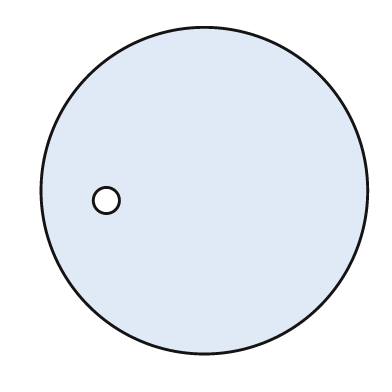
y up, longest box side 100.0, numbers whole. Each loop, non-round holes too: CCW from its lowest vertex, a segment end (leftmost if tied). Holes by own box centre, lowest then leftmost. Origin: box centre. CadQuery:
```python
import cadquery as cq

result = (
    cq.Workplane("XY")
    .moveTo(0.0, 0.0)
    .circle(50.0)
    .moveTo(-30.0, -3.0)
    .circle(4.0)
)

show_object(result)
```